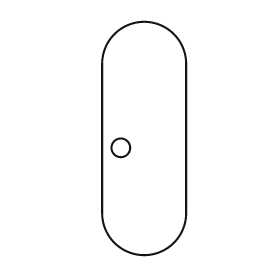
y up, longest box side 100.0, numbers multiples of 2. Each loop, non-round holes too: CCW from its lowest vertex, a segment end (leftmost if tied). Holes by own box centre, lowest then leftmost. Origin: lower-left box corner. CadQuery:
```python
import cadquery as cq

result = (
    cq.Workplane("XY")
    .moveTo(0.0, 18.0)
    .threePointArc((18.0, 0.0), (36.0, 18.0))
    .lineTo(36.0, 82.0)
    .threePointArc((18.0, 100.0), (0.0, 82.0))
    .close()
    .moveTo(8.0, 46.0)
    .circle(4.0)
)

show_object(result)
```